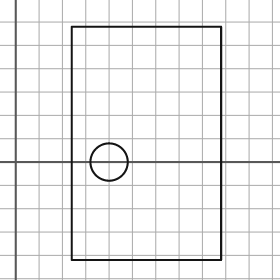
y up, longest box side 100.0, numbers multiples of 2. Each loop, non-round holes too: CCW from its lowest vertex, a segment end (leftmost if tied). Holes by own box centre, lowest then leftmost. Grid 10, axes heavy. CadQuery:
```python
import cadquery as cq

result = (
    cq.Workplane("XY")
    .moveTo(24.0, -42.0)
    .lineTo(88.0, -42.0)
    .lineTo(88.0, 58.0)
    .lineTo(24.0, 58.0)
    .close()
    .moveTo(40.0, 0.0)
    .circle(8.0)
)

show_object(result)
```